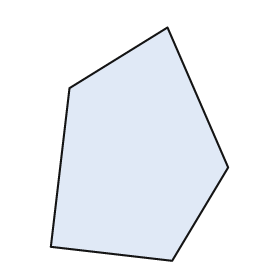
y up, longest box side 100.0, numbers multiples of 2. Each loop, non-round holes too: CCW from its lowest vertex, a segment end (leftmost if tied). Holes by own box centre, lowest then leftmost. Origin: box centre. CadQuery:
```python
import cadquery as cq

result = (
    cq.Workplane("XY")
    .moveTo(14.0, -50.0)
    .lineTo(38.0, -10.0)
    .lineTo(12.0, 50.0)
    .lineTo(-30.0, 24.0)
    .lineTo(-38.0, -44.0)
    .close()
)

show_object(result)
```